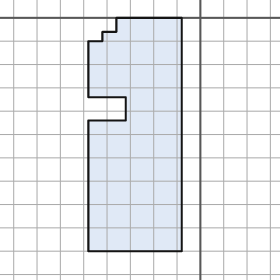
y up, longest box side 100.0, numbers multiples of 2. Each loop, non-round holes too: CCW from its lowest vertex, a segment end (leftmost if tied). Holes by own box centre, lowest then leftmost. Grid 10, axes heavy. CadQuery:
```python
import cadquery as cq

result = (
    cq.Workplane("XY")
    .moveTo(-48.0, -100.0)
    .lineTo(-8.0, -100.0)
    .lineTo(-8.0, 0.0)
    .lineTo(-36.0, 0.0)
    .lineTo(-36.0, -6.0)
    .lineTo(-42.0, -6.0)
    .lineTo(-42.0, -10.0)
    .lineTo(-48.0, -10.0)
    .lineTo(-48.0, -34.0)
    .lineTo(-32.0, -34.0)
    .lineTo(-32.0, -44.0)
    .lineTo(-48.0, -44.0)
    .close()
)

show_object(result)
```